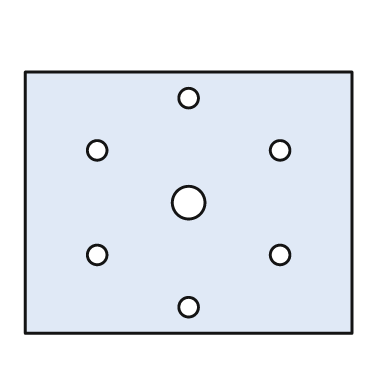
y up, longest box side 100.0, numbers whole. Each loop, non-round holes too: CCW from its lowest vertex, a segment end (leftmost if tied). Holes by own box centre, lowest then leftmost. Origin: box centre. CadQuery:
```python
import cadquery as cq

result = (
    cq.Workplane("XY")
    .moveTo(-50.0, -40.0)
    .lineTo(50.0, -40.0)
    .lineTo(50.0, 40.0)
    .lineTo(-50.0, 40.0)
    .close()
    .moveTo(0.0, -32.0)
    .circle(3.0)
    .moveTo(-28.0, -16.0)
    .circle(3.0)
    .moveTo(28.0, -16.0)
    .circle(3.0)
    .moveTo(0.0, 0.0)
    .circle(5.0)
    .moveTo(-28.0, 16.0)
    .circle(3.0)
    .moveTo(28.0, 16.0)
    .circle(3.0)
    .moveTo(0.0, 32.0)
    .circle(3.0)
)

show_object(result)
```